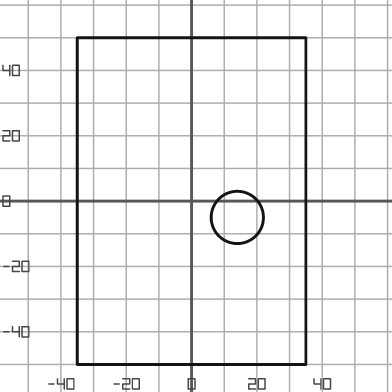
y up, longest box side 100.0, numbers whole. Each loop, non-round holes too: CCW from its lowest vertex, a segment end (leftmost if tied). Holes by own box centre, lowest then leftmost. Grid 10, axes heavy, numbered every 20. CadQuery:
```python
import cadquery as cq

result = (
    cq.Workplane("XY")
    .moveTo(-35.0, -50.0)
    .lineTo(35.0, -50.0)
    .lineTo(35.0, 50.0)
    .lineTo(-35.0, 50.0)
    .close()
    .moveTo(14.0, -5.0)
    .circle(8.0)
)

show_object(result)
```